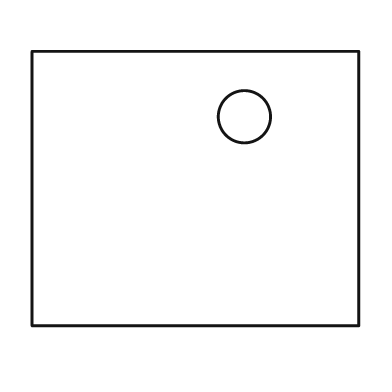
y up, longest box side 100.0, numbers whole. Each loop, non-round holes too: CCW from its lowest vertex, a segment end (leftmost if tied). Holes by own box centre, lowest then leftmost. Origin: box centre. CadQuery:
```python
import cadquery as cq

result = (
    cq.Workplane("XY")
    .moveTo(-50.0, -42.0)
    .lineTo(50.0, -42.0)
    .lineTo(50.0, 42.0)
    .lineTo(-50.0, 42.0)
    .close()
    .moveTo(15.0, 22.0)
    .circle(8.0)
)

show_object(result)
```